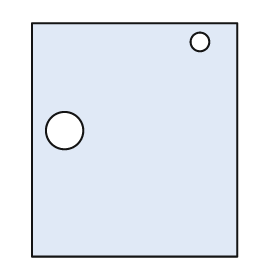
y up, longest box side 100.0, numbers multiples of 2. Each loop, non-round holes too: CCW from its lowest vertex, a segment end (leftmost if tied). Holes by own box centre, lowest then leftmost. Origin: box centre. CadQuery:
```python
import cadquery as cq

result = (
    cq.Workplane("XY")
    .moveTo(-44.0, -50.0)
    .lineTo(44.0, -50.0)
    .lineTo(44.0, 50.0)
    .lineTo(-44.0, 50.0)
    .close()
    .moveTo(-30.0, 4.0)
    .circle(8.0)
    .moveTo(28.0, 42.0)
    .circle(4.0)
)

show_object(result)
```